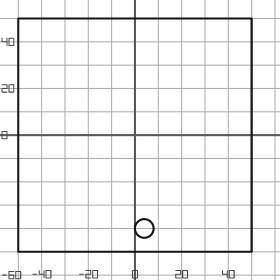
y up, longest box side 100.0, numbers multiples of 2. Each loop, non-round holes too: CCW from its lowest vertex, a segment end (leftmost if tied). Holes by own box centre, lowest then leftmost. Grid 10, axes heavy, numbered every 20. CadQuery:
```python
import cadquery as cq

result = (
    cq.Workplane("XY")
    .moveTo(-50.0, -50.0)
    .lineTo(50.0, -50.0)
    .lineTo(50.0, 50.0)
    .lineTo(-50.0, 50.0)
    .close()
    .moveTo(4.0, -40.0)
    .circle(4.0)
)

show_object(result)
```